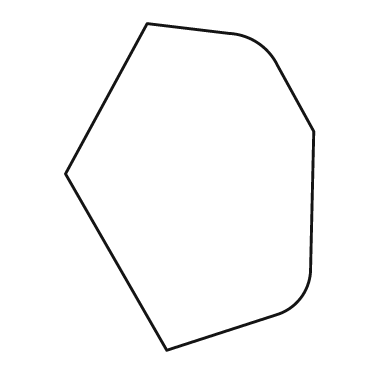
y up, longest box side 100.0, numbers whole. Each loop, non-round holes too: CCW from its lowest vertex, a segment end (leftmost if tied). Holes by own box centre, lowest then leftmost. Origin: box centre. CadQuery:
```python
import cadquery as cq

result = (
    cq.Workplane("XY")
    .moveTo(-7.0, -50.0)
    .lineTo(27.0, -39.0)
    .threePointArc((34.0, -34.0), (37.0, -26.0))
    .lineTo(38.0, 17.0)
    .lineTo(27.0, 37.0)
    .threePointArc((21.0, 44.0), (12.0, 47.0))
    .lineTo(-13.0, 50.0)
    .lineTo(-38.0, 4.0)
    .close()
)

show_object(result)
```